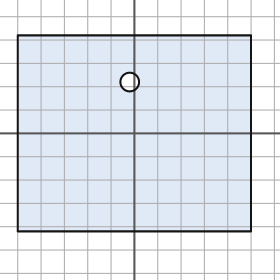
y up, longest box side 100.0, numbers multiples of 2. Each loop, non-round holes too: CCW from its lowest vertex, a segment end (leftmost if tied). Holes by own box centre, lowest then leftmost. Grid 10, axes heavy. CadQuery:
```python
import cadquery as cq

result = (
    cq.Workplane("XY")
    .moveTo(-50.0, -42.0)
    .lineTo(50.0, -42.0)
    .lineTo(50.0, 42.0)
    .lineTo(-50.0, 42.0)
    .close()
    .moveTo(-2.0, 22.0)
    .circle(4.0)
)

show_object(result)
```